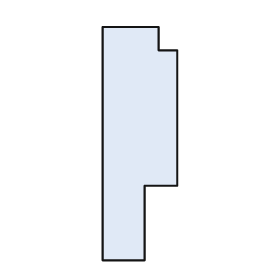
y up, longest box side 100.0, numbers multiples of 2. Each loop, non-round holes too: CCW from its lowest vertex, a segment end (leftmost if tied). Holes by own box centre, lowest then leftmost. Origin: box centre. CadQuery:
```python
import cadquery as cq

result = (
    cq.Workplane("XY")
    .moveTo(-16.0, -50.0)
    .lineTo(2.0, -50.0)
    .lineTo(2.0, -18.0)
    .lineTo(16.0, -18.0)
    .lineTo(16.0, 40.0)
    .lineTo(8.0, 40.0)
    .lineTo(8.0, 50.0)
    .lineTo(-16.0, 50.0)
    .close()
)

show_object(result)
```